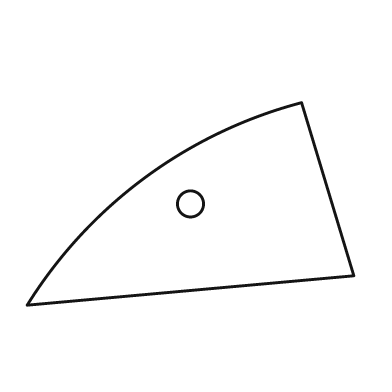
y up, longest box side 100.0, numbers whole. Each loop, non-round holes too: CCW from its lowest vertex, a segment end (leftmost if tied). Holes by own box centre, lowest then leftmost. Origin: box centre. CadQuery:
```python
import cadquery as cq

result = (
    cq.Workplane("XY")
    .moveTo(-50.0, -31.0)
    .lineTo(50.0, -22.0)
    .lineTo(34.0, 31.0)
    .threePointArc((-14.0, 8.0), (-50.0, -31.0))
    .close()
    .moveTo(0.0, 0.0)
    .circle(4.0)
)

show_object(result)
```